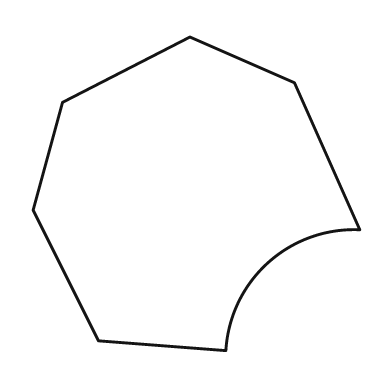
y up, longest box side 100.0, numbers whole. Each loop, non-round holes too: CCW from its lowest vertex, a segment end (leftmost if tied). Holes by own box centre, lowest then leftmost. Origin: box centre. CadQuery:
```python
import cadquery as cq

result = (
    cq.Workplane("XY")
    .moveTo(9.0, -48.0)
    .threePointArc((22.0, -21.0), (50.0, -11.0))
    .lineTo(30.0, 34.0)
    .lineTo(-2.0, 48.0)
    .lineTo(-41.0, 28.0)
    .lineTo(-50.0, -5.0)
    .lineTo(-30.0, -45.0)
    .close()
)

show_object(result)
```